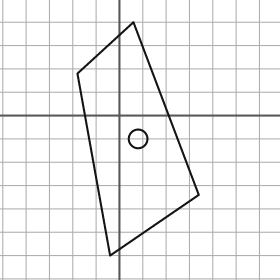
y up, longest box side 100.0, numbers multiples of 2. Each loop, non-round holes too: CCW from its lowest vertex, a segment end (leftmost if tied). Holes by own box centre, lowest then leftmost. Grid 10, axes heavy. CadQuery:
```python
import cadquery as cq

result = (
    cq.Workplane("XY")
    .moveTo(-4.0, -60.0)
    .lineTo(34.0, -34.0)
    .lineTo(6.0, 40.0)
    .lineTo(-18.0, 18.0)
    .close()
    .moveTo(8.0, -10.0)
    .circle(4.0)
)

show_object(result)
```